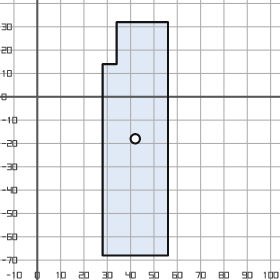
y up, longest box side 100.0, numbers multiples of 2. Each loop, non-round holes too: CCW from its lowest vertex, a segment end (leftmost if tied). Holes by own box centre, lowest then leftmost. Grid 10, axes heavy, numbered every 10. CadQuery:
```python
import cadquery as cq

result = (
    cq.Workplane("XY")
    .moveTo(28.0, -68.0)
    .lineTo(56.0, -68.0)
    .lineTo(56.0, 32.0)
    .lineTo(34.0, 32.0)
    .lineTo(34.0, 14.0)
    .lineTo(28.0, 14.0)
    .close()
    .moveTo(42.0, -18.0)
    .circle(2.0)
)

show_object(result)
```